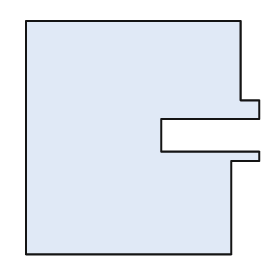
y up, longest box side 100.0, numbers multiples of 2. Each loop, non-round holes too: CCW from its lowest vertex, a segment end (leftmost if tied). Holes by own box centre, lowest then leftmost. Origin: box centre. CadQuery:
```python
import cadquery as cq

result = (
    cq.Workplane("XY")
    .moveTo(-50.0, -50.0)
    .lineTo(38.0, -50.0)
    .lineTo(38.0, -10.0)
    .lineTo(50.0, -10.0)
    .lineTo(50.0, -6.0)
    .lineTo(8.0, -6.0)
    .lineTo(8.0, 8.0)
    .lineTo(50.0, 8.0)
    .lineTo(50.0, 16.0)
    .lineTo(42.0, 16.0)
    .lineTo(42.0, 50.0)
    .lineTo(-50.0, 50.0)
    .close()
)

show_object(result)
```